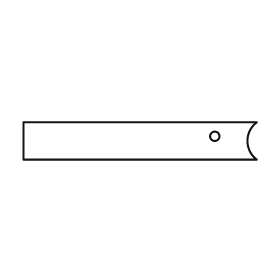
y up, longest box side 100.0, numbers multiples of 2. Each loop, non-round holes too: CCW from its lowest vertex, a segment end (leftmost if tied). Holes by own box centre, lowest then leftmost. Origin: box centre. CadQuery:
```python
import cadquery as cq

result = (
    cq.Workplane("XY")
    .moveTo(-50.0, -8.0)
    .lineTo(50.0, -8.0)
    .threePointArc((46.0, 0.0), (50.0, 8.0))
    .lineTo(-50.0, 8.0)
    .close()
    .moveTo(32.0, 2.0)
    .circle(2.0)
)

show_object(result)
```